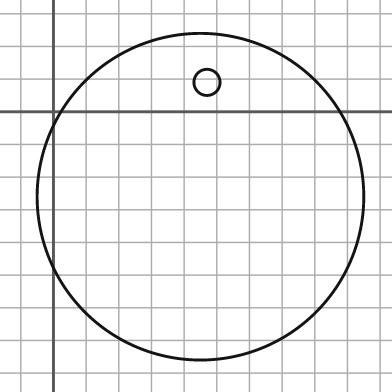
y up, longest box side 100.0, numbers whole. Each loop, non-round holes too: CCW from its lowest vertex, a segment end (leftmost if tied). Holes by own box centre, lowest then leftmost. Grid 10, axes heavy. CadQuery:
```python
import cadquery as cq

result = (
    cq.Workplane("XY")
    .moveTo(45.0, -26.0)
    .circle(50.0)
    .moveTo(47.0, 9.0)
    .circle(4.0)
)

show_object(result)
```